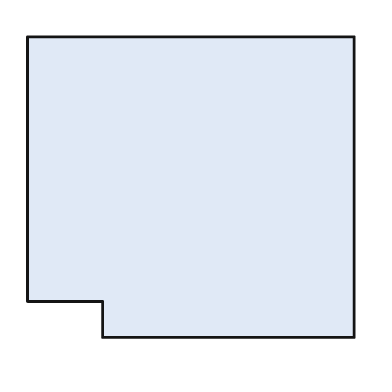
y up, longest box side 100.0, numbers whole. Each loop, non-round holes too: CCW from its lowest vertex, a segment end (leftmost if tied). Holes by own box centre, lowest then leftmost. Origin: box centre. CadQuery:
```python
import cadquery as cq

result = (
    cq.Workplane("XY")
    .moveTo(-27.0, -46.0)
    .lineTo(50.0, -46.0)
    .lineTo(50.0, 46.0)
    .lineTo(-50.0, 46.0)
    .lineTo(-50.0, -35.0)
    .lineTo(-27.0, -35.0)
    .close()
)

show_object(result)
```